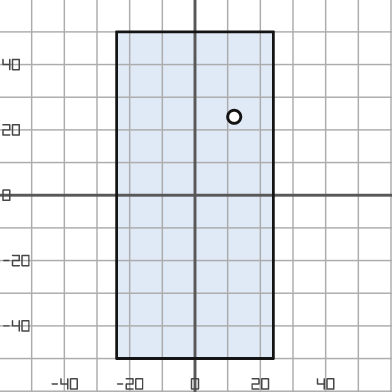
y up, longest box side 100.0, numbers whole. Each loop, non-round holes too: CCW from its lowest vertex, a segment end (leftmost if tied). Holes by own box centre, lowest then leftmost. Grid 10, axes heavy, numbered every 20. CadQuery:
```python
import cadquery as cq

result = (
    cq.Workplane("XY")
    .moveTo(-24.0, -50.0)
    .lineTo(24.0, -50.0)
    .lineTo(24.0, 50.0)
    .lineTo(-24.0, 50.0)
    .close()
    .moveTo(12.0, 24.0)
    .circle(2.0)
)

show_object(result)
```